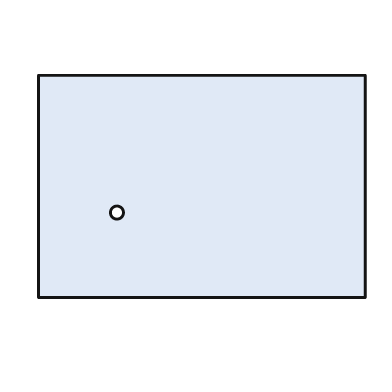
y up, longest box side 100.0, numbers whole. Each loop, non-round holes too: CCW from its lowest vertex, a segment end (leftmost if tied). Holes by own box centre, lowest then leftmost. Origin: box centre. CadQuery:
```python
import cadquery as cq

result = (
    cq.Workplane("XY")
    .moveTo(-50.0, -34.0)
    .lineTo(50.0, -34.0)
    .lineTo(50.0, 34.0)
    .lineTo(-50.0, 34.0)
    .close()
    .moveTo(-26.0, -8.0)
    .circle(2.0)
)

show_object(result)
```